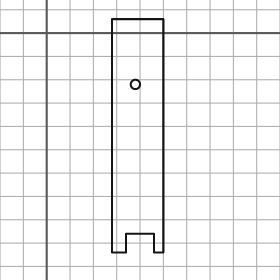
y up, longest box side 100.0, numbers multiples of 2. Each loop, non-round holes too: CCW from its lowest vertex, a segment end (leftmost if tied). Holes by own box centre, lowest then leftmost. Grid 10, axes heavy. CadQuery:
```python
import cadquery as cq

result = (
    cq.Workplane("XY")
    .moveTo(28.0, -94.0)
    .lineTo(34.0, -94.0)
    .lineTo(34.0, -86.0)
    .lineTo(46.0, -86.0)
    .lineTo(46.0, -94.0)
    .lineTo(50.0, -94.0)
    .lineTo(50.0, 6.0)
    .lineTo(28.0, 6.0)
    .close()
    .moveTo(38.0, -22.0)
    .circle(2.0)
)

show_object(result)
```